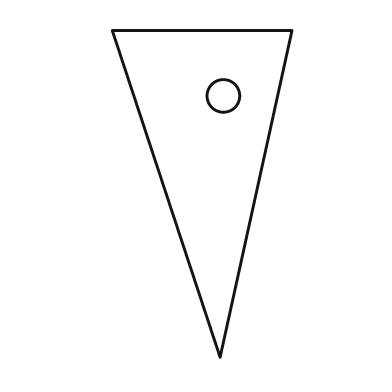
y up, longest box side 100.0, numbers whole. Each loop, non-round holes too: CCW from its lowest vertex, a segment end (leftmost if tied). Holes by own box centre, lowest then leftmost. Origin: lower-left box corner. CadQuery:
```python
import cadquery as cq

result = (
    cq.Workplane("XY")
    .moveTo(33.0, 0.0)
    .lineTo(55.0, 100.0)
    .lineTo(0.0, 100.0)
    .close()
    .moveTo(34.0, 80.0)
    .circle(5.0)
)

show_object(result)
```